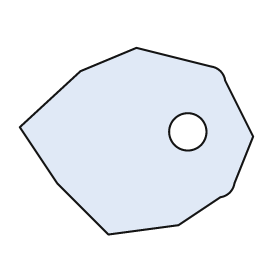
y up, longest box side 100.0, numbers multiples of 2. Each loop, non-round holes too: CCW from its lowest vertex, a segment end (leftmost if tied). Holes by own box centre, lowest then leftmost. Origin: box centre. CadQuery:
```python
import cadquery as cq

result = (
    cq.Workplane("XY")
    .moveTo(-12.0, -40.0)
    .lineTo(18.0, -36.0)
    .lineTo(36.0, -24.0)
    .threePointArc((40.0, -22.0), (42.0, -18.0))
    .lineTo(50.0, 2.0)
    .lineTo(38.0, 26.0)
    .threePointArc((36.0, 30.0), (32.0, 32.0))
    .lineTo(0.0, 40.0)
    .lineTo(-24.0, 30.0)
    .lineTo(-50.0, 6.0)
    .lineTo(-34.0, -18.0)
    .close()
    .moveTo(22.0, 4.0)
    .circle(8.0)
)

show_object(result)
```